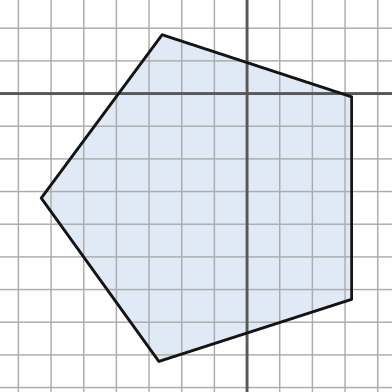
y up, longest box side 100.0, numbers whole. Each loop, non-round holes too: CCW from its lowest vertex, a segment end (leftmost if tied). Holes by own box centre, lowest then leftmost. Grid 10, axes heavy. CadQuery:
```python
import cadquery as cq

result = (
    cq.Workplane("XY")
    .moveTo(-27.0, -82.0)
    .lineTo(32.0, -63.0)
    .lineTo(32.0, -1.0)
    .lineTo(-26.0, 18.0)
    .lineTo(-63.0, -32.0)
    .close()
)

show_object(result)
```